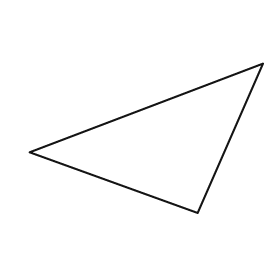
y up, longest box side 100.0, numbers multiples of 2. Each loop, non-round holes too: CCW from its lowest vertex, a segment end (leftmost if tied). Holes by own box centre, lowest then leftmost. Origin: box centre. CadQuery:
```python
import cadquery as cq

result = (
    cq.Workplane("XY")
    .moveTo(22.0, -32.0)
    .lineTo(50.0, 32.0)
    .lineTo(-50.0, -6.0)
    .close()
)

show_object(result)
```